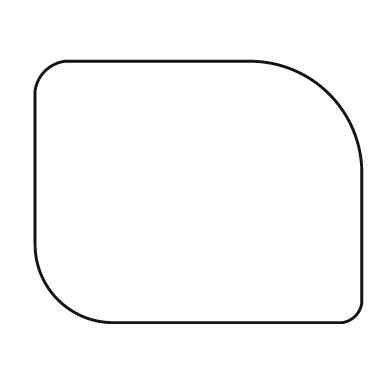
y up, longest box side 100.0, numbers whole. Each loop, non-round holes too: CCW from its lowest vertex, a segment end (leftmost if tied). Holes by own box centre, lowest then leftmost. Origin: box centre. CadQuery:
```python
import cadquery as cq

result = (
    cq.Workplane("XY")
    .moveTo(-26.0, -40.0)
    .lineTo(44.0, -40.0)
    .threePointArc((48.0, -38.0), (50.0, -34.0))
    .lineTo(50.0, 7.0)
    .threePointArc((40.0, 30.0), (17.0, 40.0))
    .lineTo(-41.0, 40.0)
    .threePointArc((-47.0, 37.0), (-50.0, 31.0))
    .lineTo(-50.0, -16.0)
    .threePointArc((-43.0, -33.0), (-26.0, -40.0))
    .close()
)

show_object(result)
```